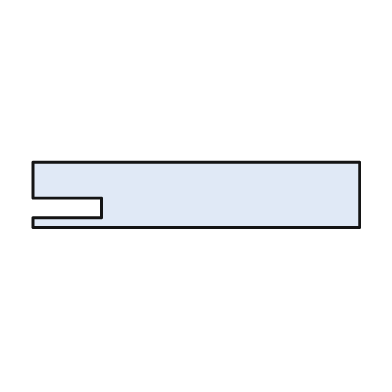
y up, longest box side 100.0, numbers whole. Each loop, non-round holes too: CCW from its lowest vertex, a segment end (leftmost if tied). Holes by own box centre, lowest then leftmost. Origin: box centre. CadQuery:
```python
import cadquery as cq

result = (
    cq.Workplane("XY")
    .moveTo(-50.0, -10.0)
    .lineTo(50.0, -10.0)
    .lineTo(50.0, 10.0)
    .lineTo(-50.0, 10.0)
    .lineTo(-50.0, -1.0)
    .lineTo(-29.0, -1.0)
    .lineTo(-29.0, -7.0)
    .lineTo(-50.0, -7.0)
    .close()
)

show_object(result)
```